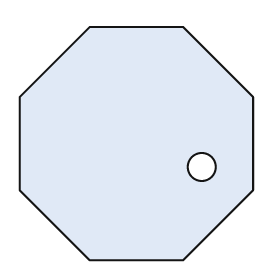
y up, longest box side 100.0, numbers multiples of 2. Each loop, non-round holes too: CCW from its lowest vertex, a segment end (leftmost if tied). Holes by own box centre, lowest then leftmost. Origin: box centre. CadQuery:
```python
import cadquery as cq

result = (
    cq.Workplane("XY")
    .moveTo(-20.0, -50.0)
    .lineTo(20.0, -50.0)
    .lineTo(50.0, -20.0)
    .lineTo(50.0, 20.0)
    .lineTo(20.0, 50.0)
    .lineTo(-20.0, 50.0)
    .lineTo(-50.0, 20.0)
    .lineTo(-50.0, -20.0)
    .close()
    .moveTo(28.0, -10.0)
    .circle(6.0)
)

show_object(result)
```